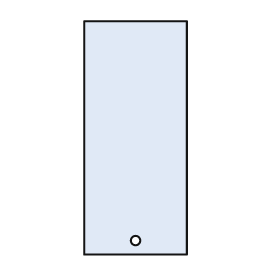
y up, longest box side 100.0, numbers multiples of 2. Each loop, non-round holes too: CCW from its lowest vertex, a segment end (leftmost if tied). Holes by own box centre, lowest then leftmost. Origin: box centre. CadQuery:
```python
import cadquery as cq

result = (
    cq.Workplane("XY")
    .moveTo(-22.0, -50.0)
    .lineTo(22.0, -50.0)
    .lineTo(22.0, 50.0)
    .lineTo(-22.0, 50.0)
    .close()
    .moveTo(0.0, -44.0)
    .circle(2.0)
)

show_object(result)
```